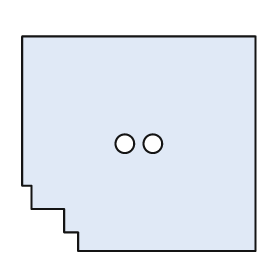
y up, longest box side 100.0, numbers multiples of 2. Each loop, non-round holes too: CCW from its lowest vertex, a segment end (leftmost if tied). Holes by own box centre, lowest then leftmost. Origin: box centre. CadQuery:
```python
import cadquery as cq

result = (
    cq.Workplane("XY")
    .moveTo(-26.0, -46.0)
    .lineTo(50.0, -46.0)
    .lineTo(50.0, 46.0)
    .lineTo(-50.0, 46.0)
    .lineTo(-50.0, -18.0)
    .lineTo(-46.0, -18.0)
    .lineTo(-46.0, -28.0)
    .lineTo(-32.0, -28.0)
    .lineTo(-32.0, -38.0)
    .lineTo(-26.0, -38.0)
    .close()
    .moveTo(-6.0, 0.0)
    .circle(4.0)
    .moveTo(6.0, 0.0)
    .circle(4.0)
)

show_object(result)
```